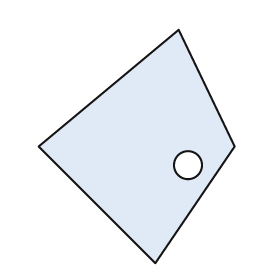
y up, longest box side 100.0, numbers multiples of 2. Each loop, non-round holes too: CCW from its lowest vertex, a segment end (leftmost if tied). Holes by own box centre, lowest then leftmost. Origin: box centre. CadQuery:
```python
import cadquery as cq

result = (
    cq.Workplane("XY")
    .moveTo(8.0, -50.0)
    .lineTo(42.0, 0.0)
    .lineTo(18.0, 50.0)
    .lineTo(-42.0, 0.0)
    .close()
    .moveTo(22.0, -8.0)
    .circle(6.0)
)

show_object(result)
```